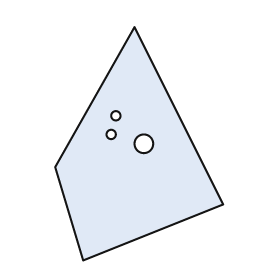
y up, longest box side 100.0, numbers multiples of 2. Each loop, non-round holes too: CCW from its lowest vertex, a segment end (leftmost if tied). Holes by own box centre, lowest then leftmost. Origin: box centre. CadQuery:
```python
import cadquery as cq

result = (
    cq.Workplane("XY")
    .moveTo(-24.0, -50.0)
    .lineTo(36.0, -26.0)
    .lineTo(-2.0, 50.0)
    .lineTo(-36.0, -10.0)
    .close()
    .moveTo(2.0, 0.0)
    .circle(4.0)
    .moveTo(-12.0, 4.0)
    .circle(2.0)
    .moveTo(-10.0, 12.0)
    .circle(2.0)
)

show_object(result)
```